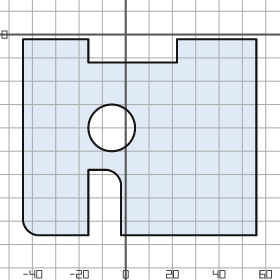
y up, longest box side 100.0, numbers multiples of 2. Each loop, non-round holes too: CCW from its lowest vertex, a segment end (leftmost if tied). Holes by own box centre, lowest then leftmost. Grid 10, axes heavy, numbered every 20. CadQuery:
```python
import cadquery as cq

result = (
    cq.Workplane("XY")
    .moveTo(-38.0, -86.0)
    .lineTo(-16.0, -86.0)
    .lineTo(-16.0, -58.0)
    .lineTo(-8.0, -58.0)
    .threePointArc((-4.0, -60.0), (-2.0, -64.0))
    .lineTo(-2.0, -86.0)
    .lineTo(56.0, -86.0)
    .lineTo(56.0, -2.0)
    .lineTo(22.0, -2.0)
    .lineTo(22.0, -12.0)
    .lineTo(-16.0, -12.0)
    .lineTo(-16.0, -2.0)
    .lineTo(-44.0, -2.0)
    .lineTo(-44.0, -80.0)
    .threePointArc((-42.0, -84.0), (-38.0, -86.0))
    .close()
    .moveTo(-6.0, -40.0)
    .circle(10.0)
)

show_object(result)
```